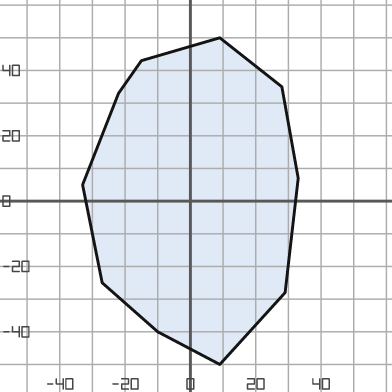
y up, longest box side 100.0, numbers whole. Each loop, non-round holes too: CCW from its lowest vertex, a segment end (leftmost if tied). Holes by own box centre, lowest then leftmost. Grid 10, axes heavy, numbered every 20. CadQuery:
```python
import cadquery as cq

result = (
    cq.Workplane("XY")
    .moveTo(9.0, -50.0)
    .lineTo(29.0, -28.0)
    .lineTo(33.0, 7.0)
    .lineTo(28.0, 35.0)
    .lineTo(9.0, 50.0)
    .lineTo(-15.0, 43.0)
    .lineTo(-22.0, 33.0)
    .lineTo(-33.0, 5.0)
    .lineTo(-27.0, -25.0)
    .lineTo(-10.0, -40.0)
    .close()
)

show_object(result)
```